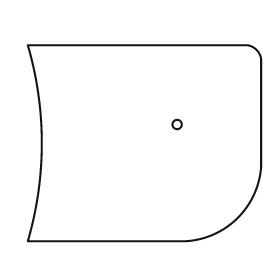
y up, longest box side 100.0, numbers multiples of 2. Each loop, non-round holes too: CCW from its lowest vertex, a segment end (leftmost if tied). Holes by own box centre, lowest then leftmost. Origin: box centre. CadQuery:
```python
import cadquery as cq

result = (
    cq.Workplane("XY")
    .moveTo(-50.0, -42.0)
    .lineTo(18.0, -42.0)
    .threePointArc((40.0, -32.0), (50.0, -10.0))
    .lineTo(50.0, 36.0)
    .threePointArc((48.0, 40.0), (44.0, 42.0))
    .lineTo(-50.0, 42.0)
    .threePointArc((-44.0, 0.0), (-50.0, -42.0))
    .close()
    .moveTo(14.0, 8.0)
    .circle(2.0)
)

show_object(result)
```